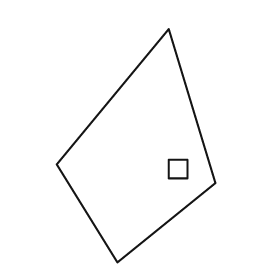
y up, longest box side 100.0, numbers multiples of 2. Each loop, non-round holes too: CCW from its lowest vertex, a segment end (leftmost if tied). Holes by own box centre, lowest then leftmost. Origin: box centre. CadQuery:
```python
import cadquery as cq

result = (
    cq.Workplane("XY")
    .moveTo(-8.0, -50.0)
    .lineTo(34.0, -16.0)
    .lineTo(14.0, 50.0)
    .lineTo(-34.0, -8.0)
    .close()
    .moveTo(14.0, -14.0)
    .lineTo(22.0, -14.0)
    .lineTo(22.0, -6.0)
    .lineTo(14.0, -6.0)
    .close()
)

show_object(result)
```